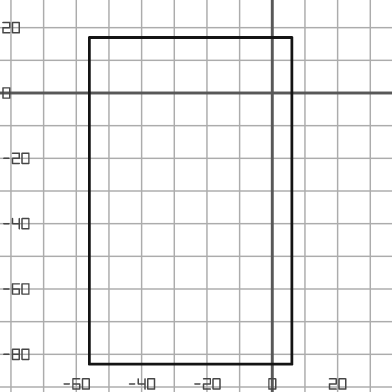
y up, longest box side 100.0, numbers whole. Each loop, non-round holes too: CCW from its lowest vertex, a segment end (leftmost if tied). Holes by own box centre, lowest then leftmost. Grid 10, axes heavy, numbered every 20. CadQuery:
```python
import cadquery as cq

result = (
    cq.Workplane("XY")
    .moveTo(-56.0, -83.0)
    .lineTo(6.0, -83.0)
    .lineTo(6.0, 17.0)
    .lineTo(-56.0, 17.0)
    .close()
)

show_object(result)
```